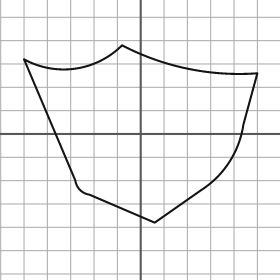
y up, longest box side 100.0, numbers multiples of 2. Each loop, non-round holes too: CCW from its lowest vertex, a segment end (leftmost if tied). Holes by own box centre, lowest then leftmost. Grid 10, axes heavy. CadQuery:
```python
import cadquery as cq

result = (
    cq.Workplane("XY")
    .moveTo(6.0, -38.0)
    .lineTo(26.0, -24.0)
    .threePointArc((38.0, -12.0), (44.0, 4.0))
    .lineTo(50.0, 26.0)
    .threePointArc((20.0, 28.0), (-8.0, 38.0))
    .threePointArc((-28.0, 28.0), (-50.0, 32.0))
    .lineTo(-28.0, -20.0)
    .threePointArc((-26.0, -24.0), (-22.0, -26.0))
    .close()
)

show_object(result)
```